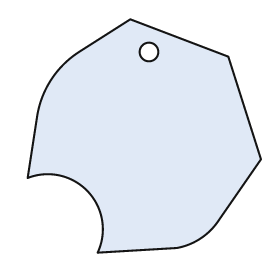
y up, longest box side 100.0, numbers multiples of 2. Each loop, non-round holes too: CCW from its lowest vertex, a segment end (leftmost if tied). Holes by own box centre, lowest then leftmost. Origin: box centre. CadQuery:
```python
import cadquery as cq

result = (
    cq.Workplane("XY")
    .moveTo(-20.0, -50.0)
    .lineTo(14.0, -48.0)
    .threePointArc((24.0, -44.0), (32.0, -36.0))
    .lineTo(50.0, -10.0)
    .lineTo(36.0, 34.0)
    .lineTo(-6.0, 50.0)
    .lineTo(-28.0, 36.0)
    .threePointArc((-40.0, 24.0), (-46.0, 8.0))
    .lineTo(-50.0, -18.0)
    .threePointArc((-24.0, -24.0), (-20.0, -50.0))
    .close()
    .moveTo(2.0, 36.0)
    .circle(4.0)
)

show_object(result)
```